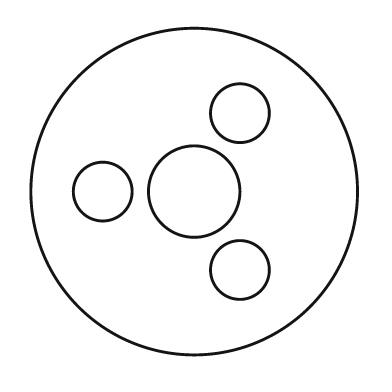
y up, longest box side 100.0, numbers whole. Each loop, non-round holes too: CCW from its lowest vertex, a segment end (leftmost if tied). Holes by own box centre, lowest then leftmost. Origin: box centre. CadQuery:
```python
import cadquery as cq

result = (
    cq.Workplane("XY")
    .moveTo(0.0, 0.0)
    .circle(50.0)
    .moveTo(14.0, -24.0)
    .circle(9.0)
    .moveTo(-28.0, 0.0)
    .circle(9.0)
    .moveTo(0.0, 0.0)
    .circle(14.0)
    .moveTo(14.0, 24.0)
    .circle(9.0)
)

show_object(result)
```